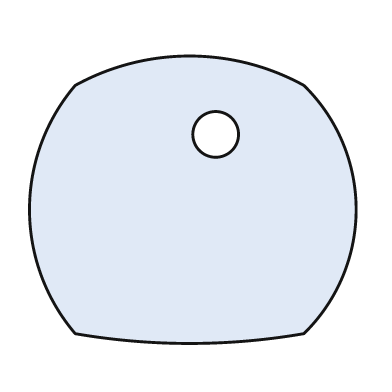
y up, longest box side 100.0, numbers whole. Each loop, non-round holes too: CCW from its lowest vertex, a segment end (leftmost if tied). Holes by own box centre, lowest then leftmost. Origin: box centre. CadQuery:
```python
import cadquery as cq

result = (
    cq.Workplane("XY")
    .moveTo(-36.0, -41.0)
    .threePointArc((-1.0, -44.0), (34.0, -41.0))
    .threePointArc((50.0, -3.0), (34.0, 35.0))
    .threePointArc((-1.0, 44.0), (-36.0, 35.0))
    .threePointArc((-50.0, -3.0), (-36.0, -41.0))
    .close()
    .moveTo(7.0, 20.0)
    .circle(7.0)
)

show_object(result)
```